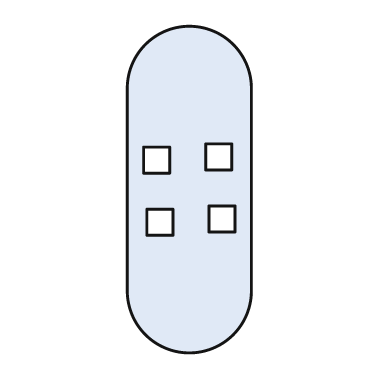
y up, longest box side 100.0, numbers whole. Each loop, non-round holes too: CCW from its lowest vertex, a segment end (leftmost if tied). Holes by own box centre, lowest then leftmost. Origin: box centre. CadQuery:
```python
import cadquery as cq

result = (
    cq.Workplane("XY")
    .moveTo(-19.0, -31.0)
    .threePointArc((0.0, -50.0), (19.0, -31.0))
    .lineTo(19.0, 31.0)
    .threePointArc((0.0, 50.0), (-19.0, 31.0))
    .close()
    .moveTo(-13.0, -14.0)
    .lineTo(-5.0, -14.0)
    .lineTo(-5.0, -6.0)
    .lineTo(-13.0, -6.0)
    .close()
    .moveTo(6.0, -13.0)
    .lineTo(14.0, -13.0)
    .lineTo(14.0, -5.0)
    .lineTo(6.0, -5.0)
    .close()
    .moveTo(-14.0, 5.0)
    .lineTo(-6.0, 5.0)
    .lineTo(-6.0, 13.0)
    .lineTo(-14.0, 13.0)
    .close()
    .moveTo(5.0, 6.0)
    .lineTo(13.0, 6.0)
    .lineTo(13.0, 14.0)
    .lineTo(5.0, 14.0)
    .close()
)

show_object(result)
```